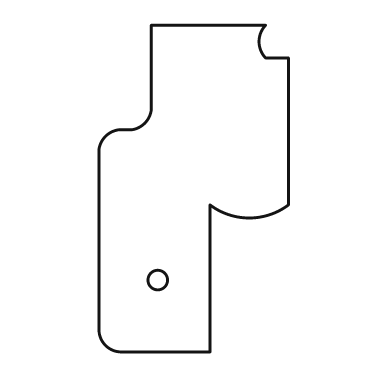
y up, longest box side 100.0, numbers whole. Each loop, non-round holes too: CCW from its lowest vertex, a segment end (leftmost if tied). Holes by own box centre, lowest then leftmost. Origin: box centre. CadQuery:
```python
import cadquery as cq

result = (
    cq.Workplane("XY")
    .moveTo(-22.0, -50.0)
    .lineTo(5.0, -50.0)
    .lineTo(5.0, -5.0)
    .threePointArc((17.0, -9.0), (29.0, -5.0))
    .lineTo(29.0, 40.0)
    .lineTo(22.0, 40.0)
    .threePointArc((20.0, 45.0), (22.0, 50.0))
    .lineTo(-13.0, 50.0)
    .lineTo(-13.0, 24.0)
    .threePointArc((-15.0, 20.0), (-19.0, 18.0))
    .lineTo(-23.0, 18.0)
    .threePointArc((-27.0, 16.0), (-29.0, 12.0))
    .lineTo(-29.0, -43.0)
    .threePointArc((-27.0, -48.0), (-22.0, -50.0))
    .close()
    .moveTo(-11.0, -28.0)
    .circle(3.0)
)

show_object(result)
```